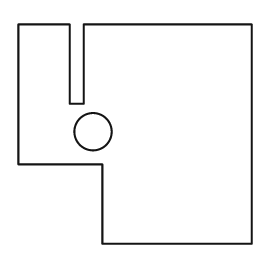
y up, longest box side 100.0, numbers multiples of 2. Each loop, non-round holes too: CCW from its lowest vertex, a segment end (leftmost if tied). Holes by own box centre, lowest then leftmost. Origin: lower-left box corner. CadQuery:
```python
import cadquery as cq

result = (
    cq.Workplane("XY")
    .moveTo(36.0, 0.0)
    .lineTo(100.0, 0.0)
    .lineTo(100.0, 94.0)
    .lineTo(28.0, 94.0)
    .lineTo(28.0, 60.0)
    .lineTo(22.0, 60.0)
    .lineTo(22.0, 94.0)
    .lineTo(0.0, 94.0)
    .lineTo(0.0, 34.0)
    .lineTo(36.0, 34.0)
    .close()
    .moveTo(32.0, 48.0)
    .circle(8.0)
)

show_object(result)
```